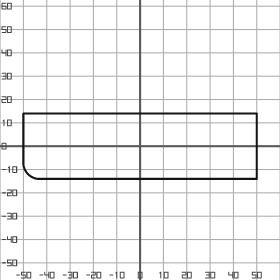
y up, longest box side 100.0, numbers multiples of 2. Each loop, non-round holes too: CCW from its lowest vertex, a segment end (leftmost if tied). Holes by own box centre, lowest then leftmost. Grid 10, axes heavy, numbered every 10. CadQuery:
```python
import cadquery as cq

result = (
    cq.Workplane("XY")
    .moveTo(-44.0, -14.0)
    .lineTo(50.0, -14.0)
    .lineTo(50.0, 14.0)
    .lineTo(-50.0, 14.0)
    .lineTo(-50.0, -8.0)
    .threePointArc((-48.0, -12.0), (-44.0, -14.0))
    .close()
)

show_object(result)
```